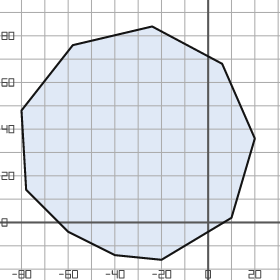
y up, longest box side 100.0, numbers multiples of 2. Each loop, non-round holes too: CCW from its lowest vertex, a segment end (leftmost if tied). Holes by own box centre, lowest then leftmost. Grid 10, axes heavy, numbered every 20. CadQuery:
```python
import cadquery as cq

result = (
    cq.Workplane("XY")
    .moveTo(-20.0, -16.0)
    .lineTo(10.0, 2.0)
    .lineTo(20.0, 36.0)
    .lineTo(6.0, 68.0)
    .lineTo(-24.0, 84.0)
    .lineTo(-58.0, 76.0)
    .lineTo(-80.0, 48.0)
    .lineTo(-78.0, 14.0)
    .lineTo(-60.0, -4.0)
    .lineTo(-40.0, -14.0)
    .close()
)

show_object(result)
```